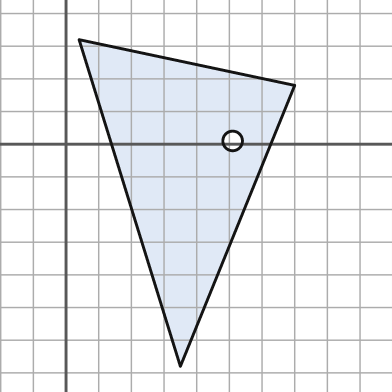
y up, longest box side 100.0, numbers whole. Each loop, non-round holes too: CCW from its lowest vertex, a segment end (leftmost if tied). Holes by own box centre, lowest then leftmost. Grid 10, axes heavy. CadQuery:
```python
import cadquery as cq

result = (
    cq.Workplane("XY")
    .moveTo(35.0, -68.0)
    .lineTo(70.0, 18.0)
    .lineTo(4.0, 32.0)
    .close()
    .moveTo(51.0, 1.0)
    .circle(3.0)
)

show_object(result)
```